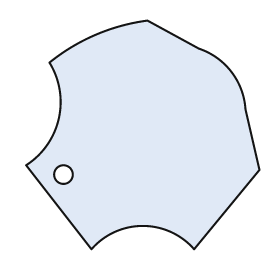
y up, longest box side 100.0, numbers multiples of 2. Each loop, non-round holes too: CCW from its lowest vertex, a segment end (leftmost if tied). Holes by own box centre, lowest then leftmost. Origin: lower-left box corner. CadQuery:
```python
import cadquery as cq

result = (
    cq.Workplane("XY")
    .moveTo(28.0, 0.0)
    .threePointArc((50.0, 10.0), (72.0, 0.0))
    .lineTo(100.0, 34.0)
    .lineTo(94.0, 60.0)
    .threePointArc((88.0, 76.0), (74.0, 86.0))
    .lineTo(52.0, 98.0)
    .threePointArc((30.0, 92.0), (10.0, 80.0))
    .threePointArc((14.0, 56.0), (0.0, 36.0))
    .close()
    .moveTo(16.0, 32.0)
    .circle(4.0)
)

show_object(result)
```